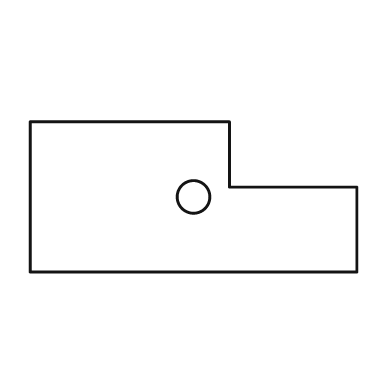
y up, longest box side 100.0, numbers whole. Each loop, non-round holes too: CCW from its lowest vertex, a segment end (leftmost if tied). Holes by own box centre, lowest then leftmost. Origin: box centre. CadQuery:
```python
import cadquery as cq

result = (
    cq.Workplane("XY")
    .moveTo(-50.0, -23.0)
    .lineTo(50.0, -23.0)
    .lineTo(50.0, 3.0)
    .lineTo(11.0, 3.0)
    .lineTo(11.0, 23.0)
    .lineTo(-50.0, 23.0)
    .close()
    .moveTo(0.0, 0.0)
    .circle(5.0)
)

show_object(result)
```